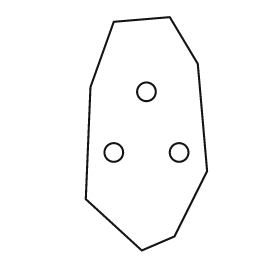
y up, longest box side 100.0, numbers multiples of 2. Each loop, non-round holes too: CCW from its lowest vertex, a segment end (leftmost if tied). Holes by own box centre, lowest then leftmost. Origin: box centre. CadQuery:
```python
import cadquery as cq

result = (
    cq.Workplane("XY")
    .moveTo(-2.0, -50.0)
    .lineTo(12.0, -44.0)
    .lineTo(26.0, -16.0)
    .lineTo(22.0, 30.0)
    .lineTo(10.0, 50.0)
    .lineTo(-14.0, 48.0)
    .lineTo(-24.0, 20.0)
    .lineTo(-26.0, -28.0)
    .close()
    .moveTo(-14.0, -8.0)
    .circle(4.0)
    .moveTo(14.0, -8.0)
    .circle(4.0)
    .moveTo(0.0, 18.0)
    .circle(4.0)
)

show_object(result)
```